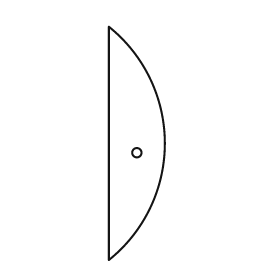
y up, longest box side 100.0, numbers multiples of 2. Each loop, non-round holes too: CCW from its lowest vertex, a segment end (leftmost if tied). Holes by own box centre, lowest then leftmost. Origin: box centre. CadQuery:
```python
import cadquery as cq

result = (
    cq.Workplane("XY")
    .moveTo(-12.0, -50.0)
    .threePointArc((12.0, 0.0), (-12.0, 50.0))
    .close()
    .moveTo(0.0, -4.0)
    .circle(2.0)
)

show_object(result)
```